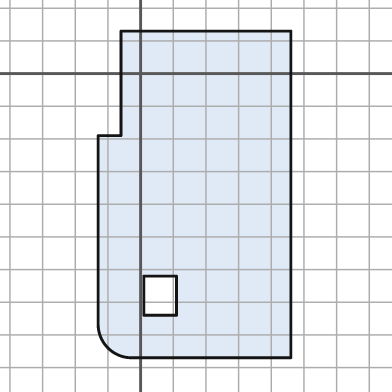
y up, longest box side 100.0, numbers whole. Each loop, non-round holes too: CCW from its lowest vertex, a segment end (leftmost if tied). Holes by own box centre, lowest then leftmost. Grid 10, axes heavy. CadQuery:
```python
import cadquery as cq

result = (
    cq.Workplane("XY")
    .moveTo(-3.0, -87.0)
    .lineTo(46.0, -87.0)
    .lineTo(46.0, 13.0)
    .lineTo(-6.0, 13.0)
    .lineTo(-6.0, -19.0)
    .lineTo(-13.0, -19.0)
    .lineTo(-13.0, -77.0)
    .threePointArc((-10.0, -84.0), (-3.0, -87.0))
    .close()
    .moveTo(1.0, -74.0)
    .lineTo(11.0, -74.0)
    .lineTo(11.0, -62.0)
    .lineTo(1.0, -62.0)
    .close()
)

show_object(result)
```